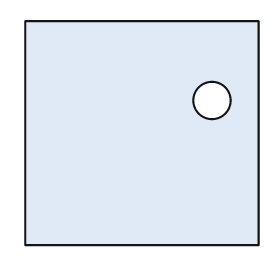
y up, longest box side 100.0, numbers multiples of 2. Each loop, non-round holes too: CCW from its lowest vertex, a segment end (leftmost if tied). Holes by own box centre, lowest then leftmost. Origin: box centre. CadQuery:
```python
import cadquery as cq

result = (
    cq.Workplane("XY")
    .moveTo(-50.0, -48.0)
    .lineTo(50.0, -48.0)
    .lineTo(50.0, 48.0)
    .lineTo(-50.0, 48.0)
    .close()
    .moveTo(30.0, 14.0)
    .circle(8.0)
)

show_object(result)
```